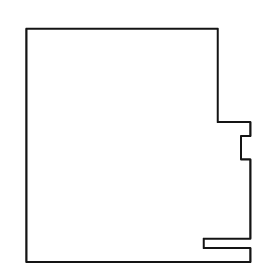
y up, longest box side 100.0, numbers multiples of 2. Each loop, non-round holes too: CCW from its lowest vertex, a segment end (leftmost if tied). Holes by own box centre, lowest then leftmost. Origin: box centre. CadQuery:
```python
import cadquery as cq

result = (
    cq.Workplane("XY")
    .moveTo(-48.0, -50.0)
    .lineTo(48.0, -50.0)
    .lineTo(48.0, -44.0)
    .lineTo(28.0, -44.0)
    .lineTo(28.0, -40.0)
    .lineTo(48.0, -40.0)
    .lineTo(48.0, -6.0)
    .lineTo(44.0, -6.0)
    .lineTo(44.0, 4.0)
    .lineTo(48.0, 4.0)
    .lineTo(48.0, 10.0)
    .lineTo(34.0, 10.0)
    .lineTo(34.0, 50.0)
    .lineTo(-48.0, 50.0)
    .close()
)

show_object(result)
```